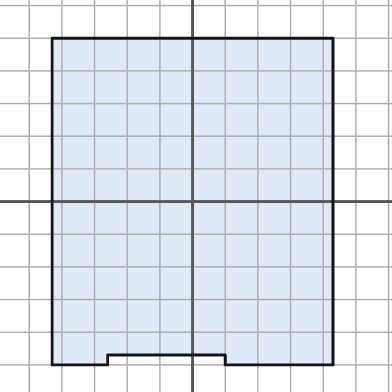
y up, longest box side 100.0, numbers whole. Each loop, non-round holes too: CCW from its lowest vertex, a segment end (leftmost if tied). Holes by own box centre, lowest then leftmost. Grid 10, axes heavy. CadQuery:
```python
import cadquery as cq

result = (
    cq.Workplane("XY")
    .moveTo(-43.0, -50.0)
    .lineTo(-26.0, -50.0)
    .lineTo(-26.0, -47.0)
    .lineTo(10.0, -47.0)
    .lineTo(10.0, -50.0)
    .lineTo(43.0, -50.0)
    .lineTo(43.0, 50.0)
    .lineTo(-43.0, 50.0)
    .close()
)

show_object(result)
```